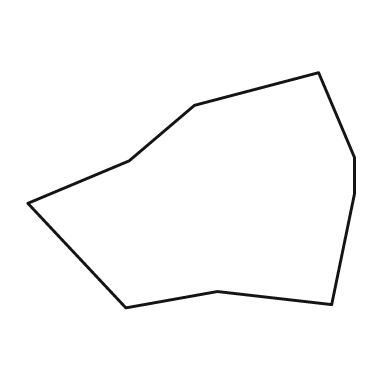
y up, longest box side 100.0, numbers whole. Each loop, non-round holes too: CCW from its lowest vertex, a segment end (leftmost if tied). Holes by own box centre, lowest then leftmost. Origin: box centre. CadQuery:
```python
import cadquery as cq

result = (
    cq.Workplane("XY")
    .moveTo(-20.0, -36.0)
    .lineTo(8.0, -31.0)
    .lineTo(43.0, -35.0)
    .lineTo(50.0, -1.0)
    .lineTo(50.0, 10.0)
    .lineTo(39.0, 36.0)
    .lineTo(1.0, 26.0)
    .lineTo(-19.0, 9.0)
    .lineTo(-50.0, -4.0)
    .close()
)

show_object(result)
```